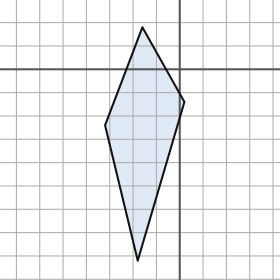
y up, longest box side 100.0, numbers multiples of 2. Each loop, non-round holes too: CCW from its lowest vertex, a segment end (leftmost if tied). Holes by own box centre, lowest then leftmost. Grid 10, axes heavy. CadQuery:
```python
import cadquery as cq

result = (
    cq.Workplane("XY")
    .moveTo(-18.0, -82.0)
    .lineTo(2.0, -14.0)
    .lineTo(-16.0, 18.0)
    .lineTo(-32.0, -24.0)
    .close()
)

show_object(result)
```